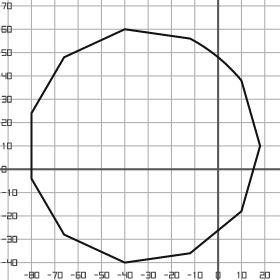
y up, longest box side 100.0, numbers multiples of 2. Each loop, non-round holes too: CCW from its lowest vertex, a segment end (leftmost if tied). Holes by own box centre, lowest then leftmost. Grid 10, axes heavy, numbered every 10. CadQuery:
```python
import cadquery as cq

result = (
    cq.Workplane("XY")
    .moveTo(-40.0, -40.0)
    .lineTo(-12.0, -36.0)
    .lineTo(10.0, -18.0)
    .lineTo(18.0, 10.0)
    .lineTo(10.0, 38.0)
    .threePointArc((0.0, 48.0), (-12.0, 56.0))
    .lineTo(-40.0, 60.0)
    .lineTo(-66.0, 48.0)
    .lineTo(-80.0, 24.0)
    .lineTo(-80.0, -4.0)
    .lineTo(-66.0, -28.0)
    .close()
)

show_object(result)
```